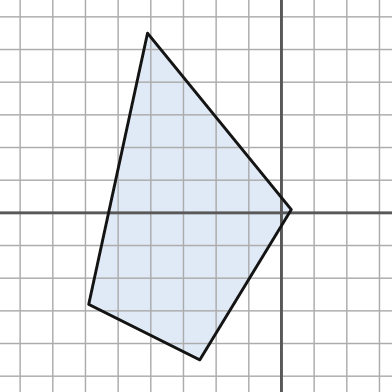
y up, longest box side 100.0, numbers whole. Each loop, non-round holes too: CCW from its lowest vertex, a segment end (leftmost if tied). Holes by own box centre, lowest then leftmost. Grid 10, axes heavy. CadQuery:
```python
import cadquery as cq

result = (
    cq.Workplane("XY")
    .moveTo(-25.0, -45.0)
    .lineTo(3.0, 1.0)
    .lineTo(-41.0, 55.0)
    .lineTo(-59.0, -28.0)
    .close()
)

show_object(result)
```